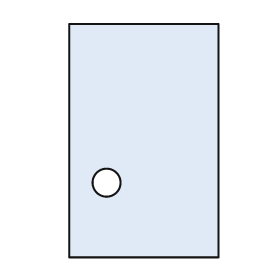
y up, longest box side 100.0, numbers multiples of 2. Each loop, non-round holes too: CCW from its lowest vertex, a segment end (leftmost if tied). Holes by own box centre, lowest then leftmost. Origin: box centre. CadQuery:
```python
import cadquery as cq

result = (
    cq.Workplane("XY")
    .moveTo(-32.0, -50.0)
    .lineTo(32.0, -50.0)
    .lineTo(32.0, 50.0)
    .lineTo(-32.0, 50.0)
    .close()
    .moveTo(-16.0, -18.0)
    .circle(6.0)
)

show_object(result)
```